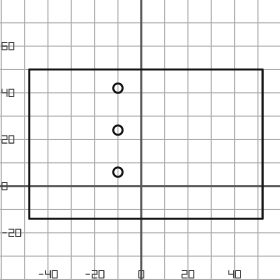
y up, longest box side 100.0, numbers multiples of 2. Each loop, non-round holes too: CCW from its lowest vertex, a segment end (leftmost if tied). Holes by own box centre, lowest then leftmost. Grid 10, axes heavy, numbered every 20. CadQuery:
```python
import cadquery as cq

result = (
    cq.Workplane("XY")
    .moveTo(-48.0, -14.0)
    .lineTo(52.0, -14.0)
    .lineTo(52.0, 50.0)
    .lineTo(-48.0, 50.0)
    .close()
    .moveTo(-10.0, 6.0)
    .circle(2.0)
    .moveTo(-10.0, 24.0)
    .circle(2.0)
    .moveTo(-10.0, 42.0)
    .circle(2.0)
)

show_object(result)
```